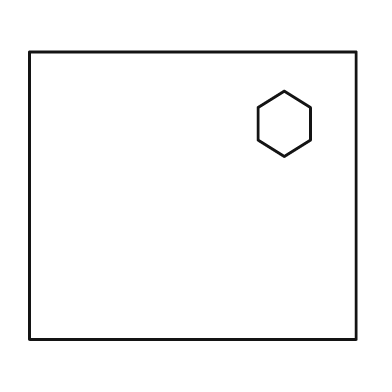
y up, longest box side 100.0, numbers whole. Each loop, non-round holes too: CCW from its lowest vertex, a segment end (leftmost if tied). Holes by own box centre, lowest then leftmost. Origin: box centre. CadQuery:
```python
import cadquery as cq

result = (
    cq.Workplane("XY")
    .moveTo(-50.0, -44.0)
    .lineTo(50.0, -44.0)
    .lineTo(50.0, 44.0)
    .lineTo(-50.0, 44.0)
    .close()
    .moveTo(28.0, 12.0)
    .lineTo(36.0, 17.0)
    .lineTo(36.0, 27.0)
    .lineTo(28.0, 32.0)
    .lineTo(20.0, 27.0)
    .lineTo(20.0, 17.0)
    .close()
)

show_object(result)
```